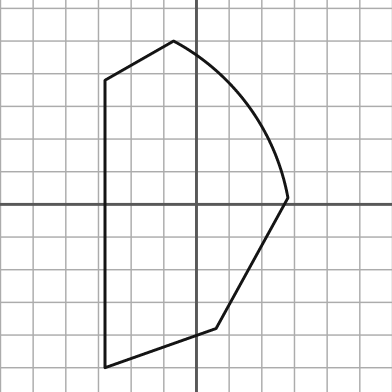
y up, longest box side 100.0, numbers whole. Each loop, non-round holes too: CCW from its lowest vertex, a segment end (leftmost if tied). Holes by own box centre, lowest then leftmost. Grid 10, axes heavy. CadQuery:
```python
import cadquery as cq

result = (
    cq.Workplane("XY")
    .moveTo(-28.0, -50.0)
    .lineTo(6.0, -38.0)
    .lineTo(28.0, 2.0)
    .threePointArc((16.0, 30.0), (-7.0, 50.0))
    .lineTo(-28.0, 38.0)
    .close()
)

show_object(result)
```